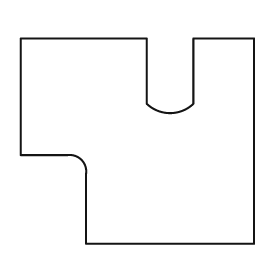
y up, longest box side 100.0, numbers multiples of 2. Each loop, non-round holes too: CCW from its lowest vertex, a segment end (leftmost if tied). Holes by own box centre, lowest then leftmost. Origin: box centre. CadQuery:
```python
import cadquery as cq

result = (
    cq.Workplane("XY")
    .moveTo(-22.0, -44.0)
    .lineTo(50.0, -44.0)
    .lineTo(50.0, 44.0)
    .lineTo(24.0, 44.0)
    .lineTo(24.0, 16.0)
    .threePointArc((14.0, 12.0), (4.0, 16.0))
    .lineTo(4.0, 44.0)
    .lineTo(-50.0, 44.0)
    .lineTo(-50.0, -6.0)
    .lineTo(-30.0, -6.0)
    .threePointArc((-24.0, -8.0), (-22.0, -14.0))
    .close()
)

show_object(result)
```